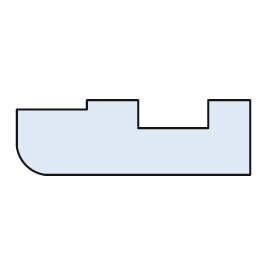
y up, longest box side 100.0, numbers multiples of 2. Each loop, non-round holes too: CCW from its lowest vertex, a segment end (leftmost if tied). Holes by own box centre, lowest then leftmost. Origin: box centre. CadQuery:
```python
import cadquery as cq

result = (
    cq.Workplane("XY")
    .moveTo(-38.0, -16.0)
    .lineTo(50.0, -16.0)
    .lineTo(50.0, 16.0)
    .lineTo(32.0, 16.0)
    .lineTo(32.0, 4.0)
    .lineTo(2.0, 4.0)
    .lineTo(2.0, 16.0)
    .lineTo(-20.0, 16.0)
    .lineTo(-20.0, 12.0)
    .lineTo(-50.0, 12.0)
    .lineTo(-50.0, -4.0)
    .threePointArc((-46.0, -12.0), (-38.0, -16.0))
    .close()
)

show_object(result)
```